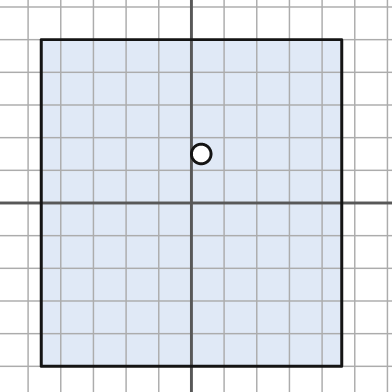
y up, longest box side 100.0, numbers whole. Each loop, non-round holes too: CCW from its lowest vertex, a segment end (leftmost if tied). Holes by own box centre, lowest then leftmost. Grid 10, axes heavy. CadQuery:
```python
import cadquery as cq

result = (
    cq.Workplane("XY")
    .moveTo(-46.0, -50.0)
    .lineTo(46.0, -50.0)
    .lineTo(46.0, 50.0)
    .lineTo(-46.0, 50.0)
    .close()
    .moveTo(3.0, 15.0)
    .circle(3.0)
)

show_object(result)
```